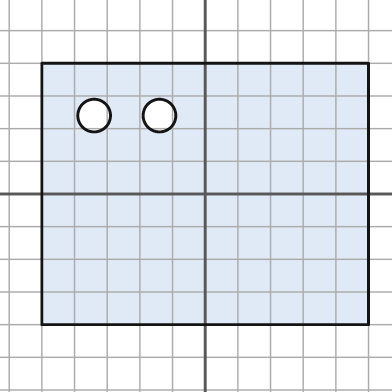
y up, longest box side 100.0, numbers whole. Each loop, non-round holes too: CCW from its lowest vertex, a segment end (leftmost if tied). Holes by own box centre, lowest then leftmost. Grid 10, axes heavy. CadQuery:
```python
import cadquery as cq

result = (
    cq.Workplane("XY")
    .moveTo(-50.0, -40.0)
    .lineTo(50.0, -40.0)
    .lineTo(50.0, 40.0)
    .lineTo(-50.0, 40.0)
    .close()
    .moveTo(-34.0, 24.0)
    .circle(5.0)
    .moveTo(-14.0, 24.0)
    .circle(5.0)
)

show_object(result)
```